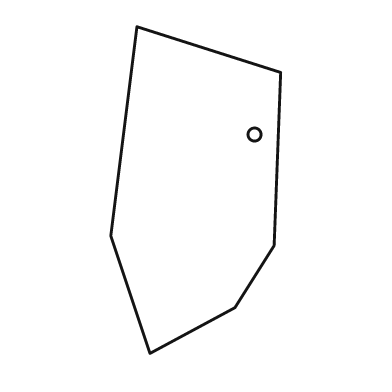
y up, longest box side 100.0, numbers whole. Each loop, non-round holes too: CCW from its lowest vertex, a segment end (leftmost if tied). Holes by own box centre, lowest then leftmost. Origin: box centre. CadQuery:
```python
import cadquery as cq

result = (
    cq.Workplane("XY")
    .moveTo(-14.0, -50.0)
    .lineTo(12.0, -36.0)
    .lineTo(24.0, -17.0)
    .lineTo(26.0, 36.0)
    .lineTo(-18.0, 50.0)
    .lineTo(-26.0, -14.0)
    .close()
    .moveTo(18.0, 17.0)
    .circle(2.0)
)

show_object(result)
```